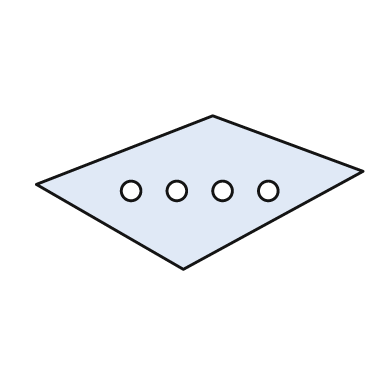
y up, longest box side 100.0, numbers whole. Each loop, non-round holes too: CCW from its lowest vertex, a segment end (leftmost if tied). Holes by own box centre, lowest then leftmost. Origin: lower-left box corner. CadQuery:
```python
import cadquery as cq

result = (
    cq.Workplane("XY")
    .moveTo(45.0, 0.0)
    .lineTo(100.0, 30.0)
    .lineTo(54.0, 47.0)
    .lineTo(0.0, 26.0)
    .close()
    .moveTo(29.0, 24.0)
    .circle(3.0)
    .moveTo(43.0, 24.0)
    .circle(3.0)
    .moveTo(57.0, 24.0)
    .circle(3.0)
    .moveTo(71.0, 24.0)
    .circle(3.0)
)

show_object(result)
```